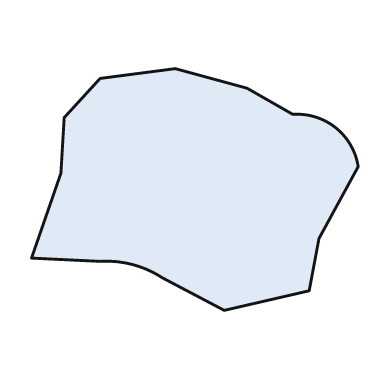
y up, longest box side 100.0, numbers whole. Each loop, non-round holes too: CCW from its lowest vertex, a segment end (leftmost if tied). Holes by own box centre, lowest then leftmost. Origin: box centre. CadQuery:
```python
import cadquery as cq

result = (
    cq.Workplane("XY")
    .moveTo(9.0, -37.0)
    .lineTo(35.0, -31.0)
    .lineTo(38.0, -15.0)
    .lineTo(50.0, 7.0)
    .threePointArc((43.0, 19.0), (30.0, 23.0))
    .lineTo(16.0, 31.0)
    .lineTo(-6.0, 37.0)
    .lineTo(-29.0, 34.0)
    .lineTo(-40.0, 22.0)
    .lineTo(-41.0, 5.0)
    .lineTo(-50.0, -21.0)
    .lineTo(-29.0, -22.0)
    .threePointArc((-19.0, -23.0), (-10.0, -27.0))
    .close()
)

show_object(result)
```